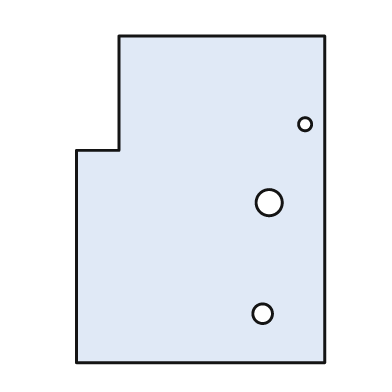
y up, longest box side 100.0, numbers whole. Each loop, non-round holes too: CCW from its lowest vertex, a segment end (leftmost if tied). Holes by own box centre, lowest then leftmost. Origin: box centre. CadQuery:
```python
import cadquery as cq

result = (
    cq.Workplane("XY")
    .moveTo(-38.0, -50.0)
    .lineTo(38.0, -50.0)
    .lineTo(38.0, 50.0)
    .lineTo(-25.0, 50.0)
    .lineTo(-25.0, 15.0)
    .lineTo(-38.0, 15.0)
    .close()
    .moveTo(19.0, -35.0)
    .circle(3.0)
    .moveTo(21.0, -1.0)
    .circle(4.0)
    .moveTo(32.0, 23.0)
    .circle(2.0)
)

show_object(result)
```